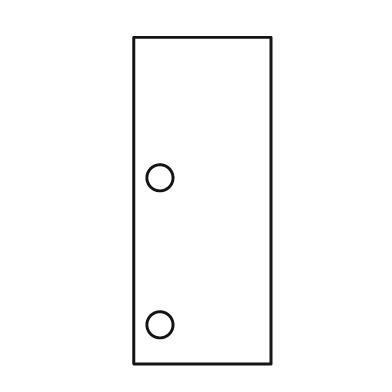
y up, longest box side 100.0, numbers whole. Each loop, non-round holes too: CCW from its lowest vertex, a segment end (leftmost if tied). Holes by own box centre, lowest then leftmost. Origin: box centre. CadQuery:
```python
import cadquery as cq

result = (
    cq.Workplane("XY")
    .moveTo(-21.0, -50.0)
    .lineTo(21.0, -50.0)
    .lineTo(21.0, 50.0)
    .lineTo(-21.0, 50.0)
    .close()
    .moveTo(-13.0, -38.0)
    .circle(4.0)
    .moveTo(-13.0, 7.0)
    .circle(4.0)
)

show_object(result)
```